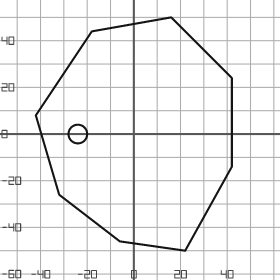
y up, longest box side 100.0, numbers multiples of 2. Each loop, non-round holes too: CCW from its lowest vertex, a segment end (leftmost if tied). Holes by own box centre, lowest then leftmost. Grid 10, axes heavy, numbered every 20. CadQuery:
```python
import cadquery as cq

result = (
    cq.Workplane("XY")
    .moveTo(22.0, -50.0)
    .lineTo(42.0, -14.0)
    .lineTo(42.0, 24.0)
    .lineTo(16.0, 50.0)
    .lineTo(-18.0, 44.0)
    .lineTo(-42.0, 8.0)
    .lineTo(-32.0, -26.0)
    .lineTo(-6.0, -46.0)
    .close()
    .moveTo(-24.0, 0.0)
    .circle(4.0)
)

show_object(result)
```